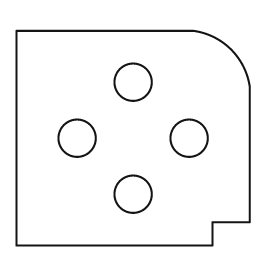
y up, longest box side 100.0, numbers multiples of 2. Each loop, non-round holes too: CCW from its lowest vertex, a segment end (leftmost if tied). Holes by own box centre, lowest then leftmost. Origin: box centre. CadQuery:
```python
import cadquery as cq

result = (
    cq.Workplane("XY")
    .moveTo(-50.0, -46.0)
    .lineTo(34.0, -46.0)
    .lineTo(34.0, -36.0)
    .lineTo(50.0, -36.0)
    .lineTo(50.0, 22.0)
    .threePointArc((42.0, 38.0), (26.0, 46.0))
    .lineTo(-50.0, 46.0)
    .close()
    .moveTo(0.0, -24.0)
    .circle(8.0)
    .moveTo(-24.0, 0.0)
    .circle(8.0)
    .moveTo(24.0, 0.0)
    .circle(8.0)
    .moveTo(0.0, 24.0)
    .circle(8.0)
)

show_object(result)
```